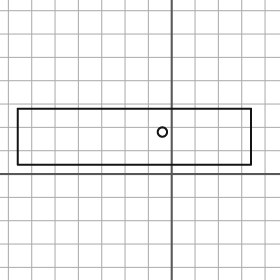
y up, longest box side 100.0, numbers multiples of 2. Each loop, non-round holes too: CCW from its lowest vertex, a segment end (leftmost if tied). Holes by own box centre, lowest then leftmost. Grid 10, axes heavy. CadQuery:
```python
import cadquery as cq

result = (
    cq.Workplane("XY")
    .moveTo(-66.0, 4.0)
    .lineTo(34.0, 4.0)
    .lineTo(34.0, 28.0)
    .lineTo(-66.0, 28.0)
    .close()
    .moveTo(-4.0, 18.0)
    .circle(2.0)
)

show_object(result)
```